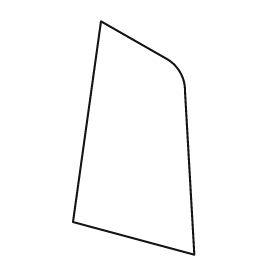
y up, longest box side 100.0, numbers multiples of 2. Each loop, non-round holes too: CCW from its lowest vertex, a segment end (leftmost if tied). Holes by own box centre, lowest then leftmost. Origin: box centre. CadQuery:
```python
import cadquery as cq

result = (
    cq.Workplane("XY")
    .moveTo(26.0, -50.0)
    .lineTo(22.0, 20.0)
    .threePointArc((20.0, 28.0), (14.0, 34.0))
    .lineTo(-14.0, 50.0)
    .lineTo(-26.0, -36.0)
    .close()
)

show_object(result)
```